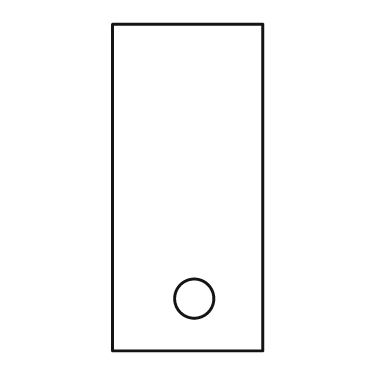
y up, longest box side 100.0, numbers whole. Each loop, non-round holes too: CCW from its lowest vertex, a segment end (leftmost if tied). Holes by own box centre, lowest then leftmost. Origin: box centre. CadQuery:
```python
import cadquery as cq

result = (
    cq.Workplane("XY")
    .moveTo(-23.0, -50.0)
    .lineTo(23.0, -50.0)
    .lineTo(23.0, 50.0)
    .lineTo(-23.0, 50.0)
    .close()
    .moveTo(2.0, -34.0)
    .circle(6.0)
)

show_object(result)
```